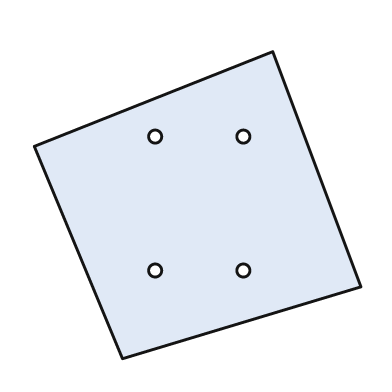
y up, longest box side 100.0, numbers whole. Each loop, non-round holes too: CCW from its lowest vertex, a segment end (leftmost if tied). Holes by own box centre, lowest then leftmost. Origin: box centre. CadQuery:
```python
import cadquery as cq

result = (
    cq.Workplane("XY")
    .moveTo(-23.0, -47.0)
    .lineTo(50.0, -25.0)
    .lineTo(23.0, 47.0)
    .lineTo(-50.0, 18.0)
    .close()
    .moveTo(-13.0, -20.0)
    .circle(2.0)
    .moveTo(14.0, -20.0)
    .circle(2.0)
    .moveTo(-13.0, 21.0)
    .circle(2.0)
    .moveTo(14.0, 21.0)
    .circle(2.0)
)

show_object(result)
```